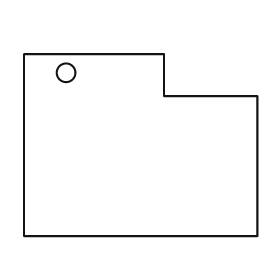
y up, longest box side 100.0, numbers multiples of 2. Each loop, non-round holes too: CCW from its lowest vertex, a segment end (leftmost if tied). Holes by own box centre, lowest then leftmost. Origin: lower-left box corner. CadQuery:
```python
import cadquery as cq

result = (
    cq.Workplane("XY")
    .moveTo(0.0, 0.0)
    .lineTo(100.0, 0.0)
    .lineTo(100.0, 60.0)
    .lineTo(60.0, 60.0)
    .lineTo(60.0, 78.0)
    .lineTo(0.0, 78.0)
    .close()
    .moveTo(18.0, 70.0)
    .circle(4.0)
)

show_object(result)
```